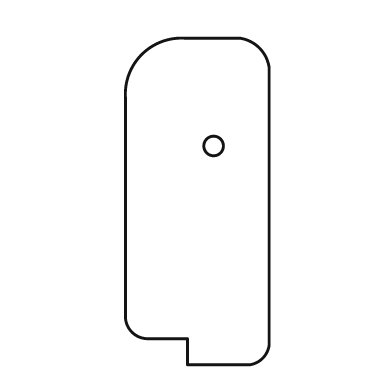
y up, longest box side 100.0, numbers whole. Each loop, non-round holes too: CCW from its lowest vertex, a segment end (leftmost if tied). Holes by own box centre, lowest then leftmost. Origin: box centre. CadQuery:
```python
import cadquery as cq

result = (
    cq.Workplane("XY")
    .moveTo(-3.0, -50.0)
    .lineTo(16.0, -50.0)
    .threePointArc((20.0, -48.0), (22.0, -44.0))
    .lineTo(22.0, 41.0)
    .threePointArc((19.0, 47.0), (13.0, 50.0))
    .lineTo(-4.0, 50.0)
    .threePointArc((-17.0, 45.0), (-22.0, 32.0))
    .lineTo(-22.0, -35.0)
    .threePointArc((-20.0, -40.0), (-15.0, -42.0))
    .lineTo(-3.0, -42.0)
    .close()
    .moveTo(5.0, 17.0)
    .circle(3.0)
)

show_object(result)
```